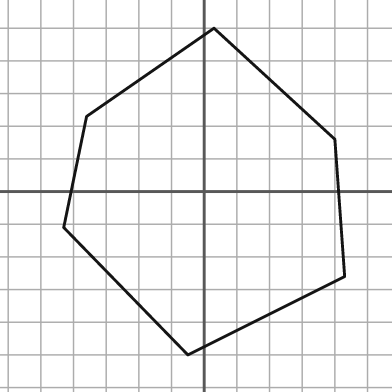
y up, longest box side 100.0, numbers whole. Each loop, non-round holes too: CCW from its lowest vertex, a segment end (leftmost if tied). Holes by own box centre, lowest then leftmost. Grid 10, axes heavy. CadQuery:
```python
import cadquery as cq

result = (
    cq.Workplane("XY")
    .moveTo(-5.0, -50.0)
    .lineTo(43.0, -26.0)
    .lineTo(40.0, 16.0)
    .lineTo(3.0, 50.0)
    .lineTo(-36.0, 23.0)
    .lineTo(-43.0, -11.0)
    .close()
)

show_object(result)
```